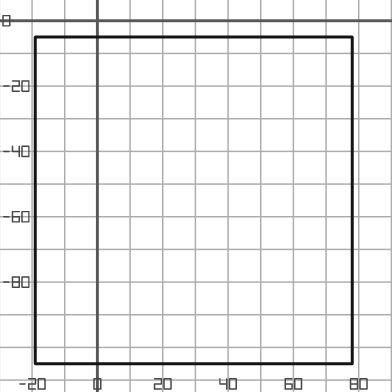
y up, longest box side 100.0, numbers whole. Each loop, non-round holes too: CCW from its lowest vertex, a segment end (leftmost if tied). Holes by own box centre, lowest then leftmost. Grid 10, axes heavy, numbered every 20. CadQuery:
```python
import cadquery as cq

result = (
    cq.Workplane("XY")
    .moveTo(-19.0, -105.0)
    .lineTo(78.0, -105.0)
    .lineTo(78.0, -5.0)
    .lineTo(-19.0, -5.0)
    .close()
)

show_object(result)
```